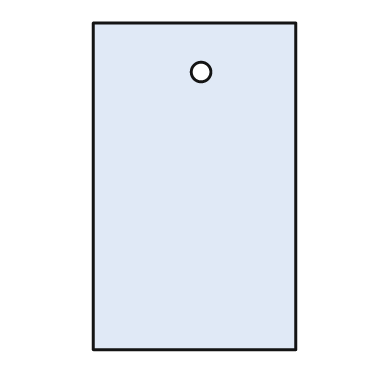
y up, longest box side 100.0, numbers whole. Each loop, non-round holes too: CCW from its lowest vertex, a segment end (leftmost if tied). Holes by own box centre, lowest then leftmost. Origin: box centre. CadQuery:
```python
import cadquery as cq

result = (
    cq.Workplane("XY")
    .moveTo(-31.0, -50.0)
    .lineTo(31.0, -50.0)
    .lineTo(31.0, 50.0)
    .lineTo(-31.0, 50.0)
    .close()
    .moveTo(2.0, 35.0)
    .circle(3.0)
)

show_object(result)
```